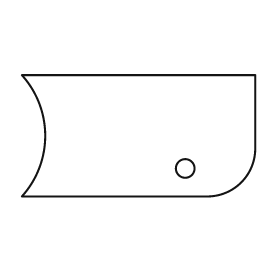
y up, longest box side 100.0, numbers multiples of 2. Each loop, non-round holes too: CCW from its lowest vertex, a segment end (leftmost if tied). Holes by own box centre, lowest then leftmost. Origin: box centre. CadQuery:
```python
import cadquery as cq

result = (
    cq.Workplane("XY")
    .moveTo(-50.0, -26.0)
    .lineTo(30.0, -26.0)
    .threePointArc((44.0, -20.0), (50.0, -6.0))
    .lineTo(50.0, 26.0)
    .lineTo(-50.0, 26.0)
    .threePointArc((-40.0, 0.0), (-50.0, -26.0))
    .close()
    .moveTo(20.0, -14.0)
    .circle(4.0)
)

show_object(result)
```